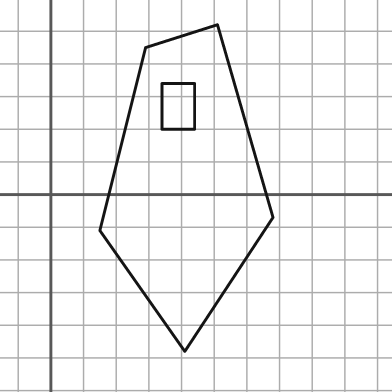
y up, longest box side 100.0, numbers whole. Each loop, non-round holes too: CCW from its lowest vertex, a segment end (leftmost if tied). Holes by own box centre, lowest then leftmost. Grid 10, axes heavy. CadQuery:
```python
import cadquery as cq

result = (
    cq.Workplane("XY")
    .moveTo(41.0, -48.0)
    .lineTo(68.0, -7.0)
    .lineTo(51.0, 52.0)
    .lineTo(29.0, 45.0)
    .lineTo(15.0, -11.0)
    .close()
    .moveTo(34.0, 20.0)
    .lineTo(44.0, 20.0)
    .lineTo(44.0, 34.0)
    .lineTo(34.0, 34.0)
    .close()
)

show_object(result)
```